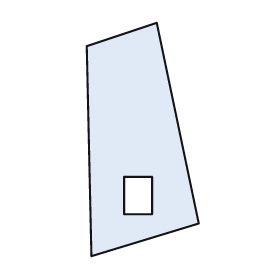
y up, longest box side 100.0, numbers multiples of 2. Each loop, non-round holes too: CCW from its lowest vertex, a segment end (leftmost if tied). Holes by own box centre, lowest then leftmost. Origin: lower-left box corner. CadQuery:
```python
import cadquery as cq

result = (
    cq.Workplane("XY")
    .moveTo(2.0, 0.0)
    .lineTo(48.0, 14.0)
    .lineTo(30.0, 100.0)
    .lineTo(0.0, 90.0)
    .close()
    .moveTo(16.0, 18.0)
    .lineTo(28.0, 18.0)
    .lineTo(28.0, 34.0)
    .lineTo(16.0, 34.0)
    .close()
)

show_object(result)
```